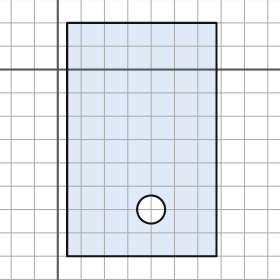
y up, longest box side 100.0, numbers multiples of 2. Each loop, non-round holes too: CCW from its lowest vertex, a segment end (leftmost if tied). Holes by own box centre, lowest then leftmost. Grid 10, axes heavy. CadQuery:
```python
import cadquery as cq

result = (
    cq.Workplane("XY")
    .moveTo(4.0, -80.0)
    .lineTo(68.0, -80.0)
    .lineTo(68.0, 20.0)
    .lineTo(4.0, 20.0)
    .close()
    .moveTo(40.0, -60.0)
    .circle(6.0)
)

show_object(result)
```